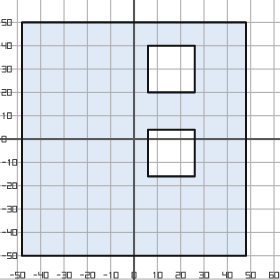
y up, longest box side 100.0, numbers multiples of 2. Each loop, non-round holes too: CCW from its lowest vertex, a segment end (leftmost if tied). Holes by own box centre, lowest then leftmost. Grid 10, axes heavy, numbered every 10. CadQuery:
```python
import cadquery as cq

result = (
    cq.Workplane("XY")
    .moveTo(-48.0, -50.0)
    .lineTo(48.0, -50.0)
    .lineTo(48.0, 50.0)
    .lineTo(-48.0, 50.0)
    .close()
    .moveTo(6.0, -16.0)
    .lineTo(26.0, -16.0)
    .lineTo(26.0, 4.0)
    .lineTo(6.0, 4.0)
    .close()
    .moveTo(6.0, 20.0)
    .lineTo(26.0, 20.0)
    .lineTo(26.0, 40.0)
    .lineTo(6.0, 40.0)
    .close()
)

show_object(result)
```